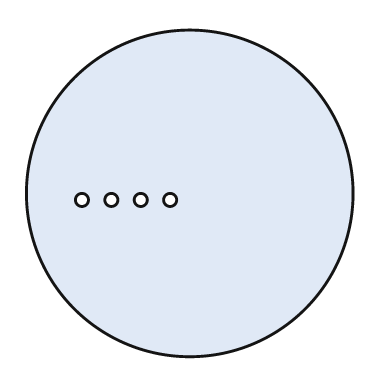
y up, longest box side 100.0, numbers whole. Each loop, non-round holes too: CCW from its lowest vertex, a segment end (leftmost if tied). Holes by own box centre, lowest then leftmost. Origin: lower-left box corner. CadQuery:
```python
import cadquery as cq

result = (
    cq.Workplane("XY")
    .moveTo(50.0, 50.0)
    .circle(50.0)
    .moveTo(17.0, 48.0)
    .circle(2.0)
    .moveTo(26.0, 48.0)
    .circle(2.0)
    .moveTo(35.0, 48.0)
    .circle(2.0)
    .moveTo(44.0, 48.0)
    .circle(2.0)
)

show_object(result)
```